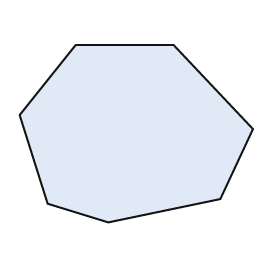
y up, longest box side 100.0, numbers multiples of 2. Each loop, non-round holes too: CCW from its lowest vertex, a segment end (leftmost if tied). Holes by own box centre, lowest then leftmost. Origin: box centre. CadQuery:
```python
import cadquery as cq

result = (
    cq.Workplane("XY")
    .moveTo(-12.0, -38.0)
    .lineTo(36.0, -28.0)
    .lineTo(50.0, 2.0)
    .lineTo(16.0, 38.0)
    .lineTo(-26.0, 38.0)
    .lineTo(-50.0, 8.0)
    .lineTo(-38.0, -30.0)
    .close()
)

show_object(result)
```